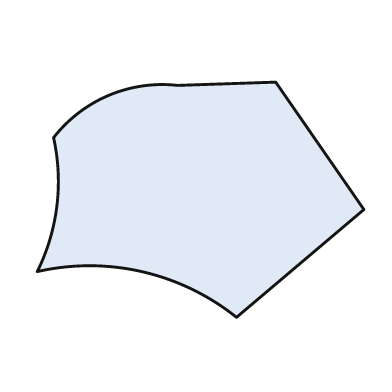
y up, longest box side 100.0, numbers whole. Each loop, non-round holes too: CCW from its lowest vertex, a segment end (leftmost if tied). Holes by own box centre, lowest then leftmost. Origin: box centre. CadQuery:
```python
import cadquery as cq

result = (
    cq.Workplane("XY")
    .moveTo(11.0, -36.0)
    .lineTo(50.0, -3.0)
    .lineTo(23.0, 36.0)
    .lineTo(-7.0, 35.0)
    .threePointArc((-28.0, 32.0), (-45.0, 19.0))
    .threePointArc((-44.0, -2.0), (-50.0, -22.0))
    .threePointArc((-18.0, -22.0), (11.0, -36.0))
    .close()
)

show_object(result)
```